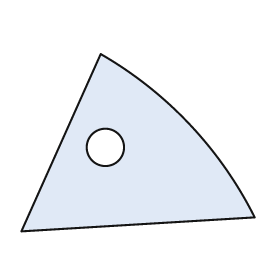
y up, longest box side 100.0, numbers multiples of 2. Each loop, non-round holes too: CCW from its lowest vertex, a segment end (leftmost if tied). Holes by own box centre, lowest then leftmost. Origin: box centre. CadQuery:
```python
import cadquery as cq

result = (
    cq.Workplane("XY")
    .moveTo(-50.0, -38.0)
    .lineTo(50.0, -32.0)
    .threePointArc((22.0, 8.0), (-16.0, 38.0))
    .close()
    .moveTo(-14.0, -2.0)
    .circle(8.0)
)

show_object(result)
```